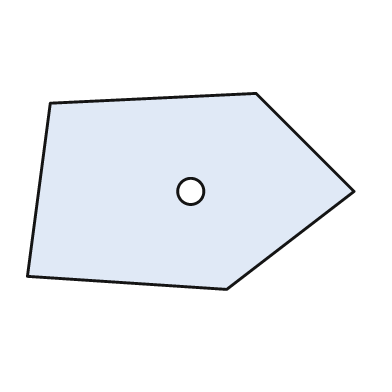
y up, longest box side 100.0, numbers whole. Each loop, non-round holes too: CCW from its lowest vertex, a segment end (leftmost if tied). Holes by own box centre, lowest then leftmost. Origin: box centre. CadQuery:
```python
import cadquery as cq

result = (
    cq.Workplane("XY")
    .moveTo(11.0, -30.0)
    .lineTo(50.0, 0.0)
    .lineTo(20.0, 30.0)
    .lineTo(-43.0, 27.0)
    .lineTo(-50.0, -26.0)
    .close()
    .moveTo(0.0, 0.0)
    .circle(4.0)
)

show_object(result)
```